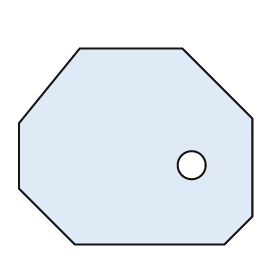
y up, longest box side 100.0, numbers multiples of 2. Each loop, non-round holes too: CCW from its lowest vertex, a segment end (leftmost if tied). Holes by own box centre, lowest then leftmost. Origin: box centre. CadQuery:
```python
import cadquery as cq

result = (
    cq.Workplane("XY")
    .moveTo(-26.0, -42.0)
    .lineTo(38.0, -42.0)
    .lineTo(50.0, -30.0)
    .lineTo(50.0, 12.0)
    .lineTo(20.0, 42.0)
    .lineTo(-24.0, 42.0)
    .lineTo(-50.0, 10.0)
    .lineTo(-50.0, -18.0)
    .close()
    .moveTo(24.0, -8.0)
    .circle(6.0)
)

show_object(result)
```